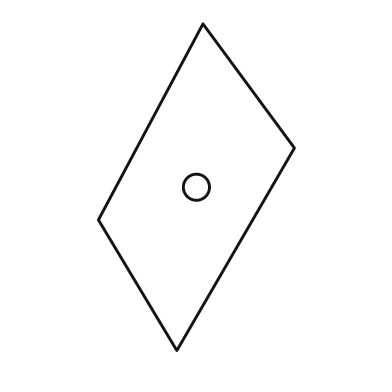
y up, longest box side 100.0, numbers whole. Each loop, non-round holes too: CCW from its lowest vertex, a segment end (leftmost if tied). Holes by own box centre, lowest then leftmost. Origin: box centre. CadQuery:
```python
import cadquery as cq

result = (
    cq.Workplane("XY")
    .moveTo(-6.0, -50.0)
    .lineTo(30.0, 12.0)
    .lineTo(2.0, 50.0)
    .lineTo(-30.0, -10.0)
    .close()
    .moveTo(0.0, 0.0)
    .circle(4.0)
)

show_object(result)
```